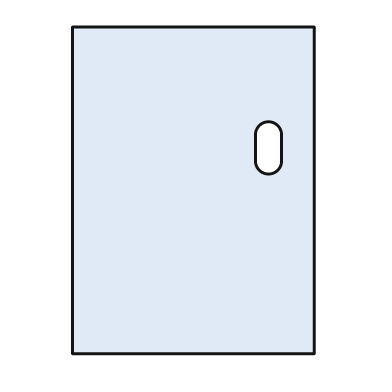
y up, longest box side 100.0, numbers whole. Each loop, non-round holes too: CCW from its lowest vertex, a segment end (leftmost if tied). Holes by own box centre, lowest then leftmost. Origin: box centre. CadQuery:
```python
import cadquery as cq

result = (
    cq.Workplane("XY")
    .moveTo(-37.0, -50.0)
    .lineTo(37.0, -50.0)
    .lineTo(37.0, 50.0)
    .lineTo(-37.0, 50.0)
    .close()
    .moveTo(19.0, 9.0)
    .threePointArc((23.0, 5.0), (27.0, 9.0))
    .lineTo(27.0, 17.0)
    .threePointArc((23.0, 21.0), (19.0, 17.0))
    .close()
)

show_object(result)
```